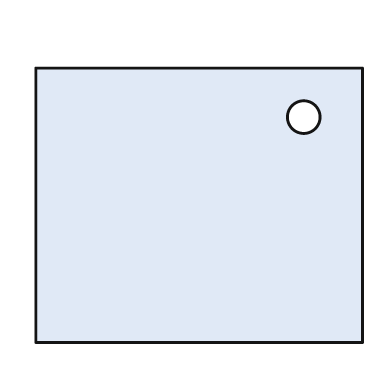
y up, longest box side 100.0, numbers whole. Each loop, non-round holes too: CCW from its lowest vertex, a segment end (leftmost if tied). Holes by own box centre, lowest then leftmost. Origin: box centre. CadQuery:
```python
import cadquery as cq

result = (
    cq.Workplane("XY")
    .moveTo(-50.0, -42.0)
    .lineTo(50.0, -42.0)
    .lineTo(50.0, 42.0)
    .lineTo(-50.0, 42.0)
    .close()
    .moveTo(32.0, 27.0)
    .circle(5.0)
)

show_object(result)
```